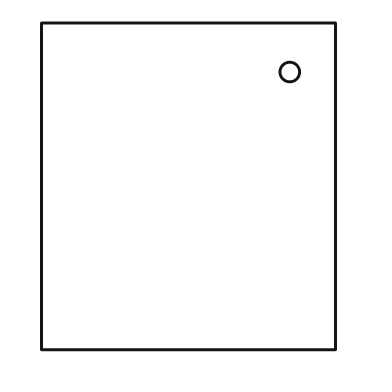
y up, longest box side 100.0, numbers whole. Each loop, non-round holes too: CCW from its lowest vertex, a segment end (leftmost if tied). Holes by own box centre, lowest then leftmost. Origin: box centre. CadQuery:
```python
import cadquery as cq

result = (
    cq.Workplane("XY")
    .moveTo(-45.0, -50.0)
    .lineTo(45.0, -50.0)
    .lineTo(45.0, 50.0)
    .lineTo(-45.0, 50.0)
    .close()
    .moveTo(31.0, 35.0)
    .circle(3.0)
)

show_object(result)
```